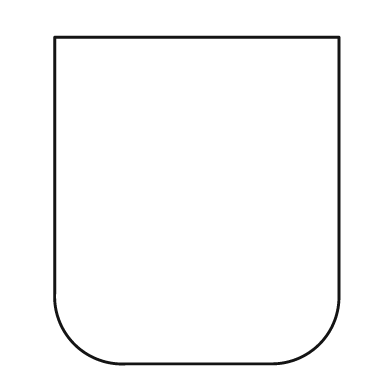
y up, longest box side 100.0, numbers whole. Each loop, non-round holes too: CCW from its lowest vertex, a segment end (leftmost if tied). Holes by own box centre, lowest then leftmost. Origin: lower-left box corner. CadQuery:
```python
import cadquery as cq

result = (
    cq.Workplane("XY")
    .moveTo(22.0, 0.0)
    .lineTo(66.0, 0.0)
    .threePointArc((81.0, 6.0), (87.0, 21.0))
    .lineTo(87.0, 100.0)
    .lineTo(0.0, 100.0)
    .lineTo(0.0, 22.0)
    .threePointArc((6.0, 6.0), (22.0, 0.0))
    .close()
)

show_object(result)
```